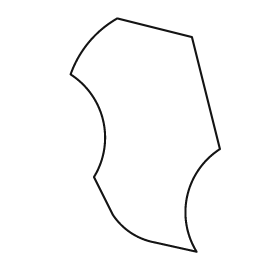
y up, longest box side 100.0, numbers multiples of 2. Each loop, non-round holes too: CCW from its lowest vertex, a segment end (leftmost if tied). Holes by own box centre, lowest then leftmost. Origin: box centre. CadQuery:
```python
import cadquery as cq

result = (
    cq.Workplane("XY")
    .moveTo(22.0, -50.0)
    .threePointArc((18.0, -26.0), (32.0, -6.0))
    .lineTo(20.0, 42.0)
    .lineTo(-12.0, 50.0)
    .threePointArc((-24.0, 40.0), (-32.0, 26.0))
    .threePointArc((-18.0, 6.0), (-22.0, -18.0))
    .lineTo(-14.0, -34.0)
    .threePointArc((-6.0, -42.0), (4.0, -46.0))
    .close()
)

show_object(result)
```